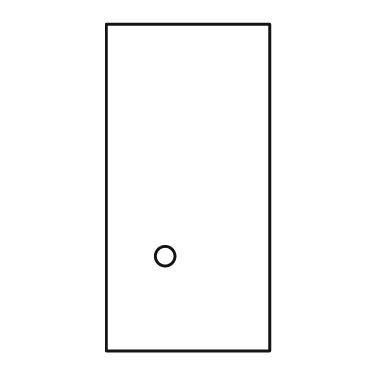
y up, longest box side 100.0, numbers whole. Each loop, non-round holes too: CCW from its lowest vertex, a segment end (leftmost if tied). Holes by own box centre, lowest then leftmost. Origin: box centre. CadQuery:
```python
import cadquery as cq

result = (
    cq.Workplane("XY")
    .moveTo(-25.0, -50.0)
    .lineTo(25.0, -50.0)
    .lineTo(25.0, 50.0)
    .lineTo(-25.0, 50.0)
    .close()
    .moveTo(-7.0, -21.0)
    .circle(3.0)
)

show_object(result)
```